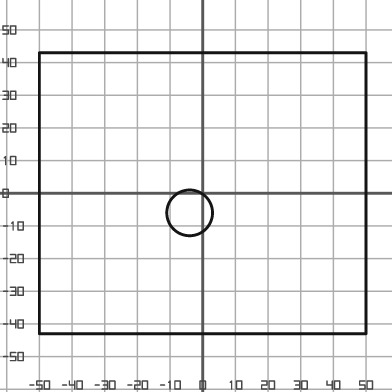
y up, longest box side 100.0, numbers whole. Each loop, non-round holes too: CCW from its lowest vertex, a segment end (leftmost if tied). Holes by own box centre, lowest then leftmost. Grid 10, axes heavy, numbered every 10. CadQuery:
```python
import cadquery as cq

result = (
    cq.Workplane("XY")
    .moveTo(-50.0, -43.0)
    .lineTo(50.0, -43.0)
    .lineTo(50.0, 43.0)
    .lineTo(-50.0, 43.0)
    .close()
    .moveTo(-4.0, -6.0)
    .circle(7.0)
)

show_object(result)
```